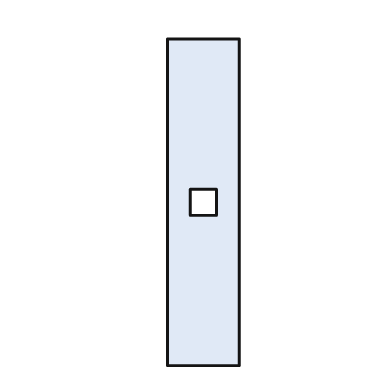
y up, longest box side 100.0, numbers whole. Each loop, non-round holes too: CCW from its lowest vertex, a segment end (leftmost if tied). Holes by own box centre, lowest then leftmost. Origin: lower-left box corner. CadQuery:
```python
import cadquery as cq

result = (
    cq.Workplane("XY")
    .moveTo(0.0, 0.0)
    .lineTo(22.0, 0.0)
    .lineTo(22.0, 100.0)
    .lineTo(0.0, 100.0)
    .close()
    .moveTo(7.0, 46.0)
    .lineTo(15.0, 46.0)
    .lineTo(15.0, 54.0)
    .lineTo(7.0, 54.0)
    .close()
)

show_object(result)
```